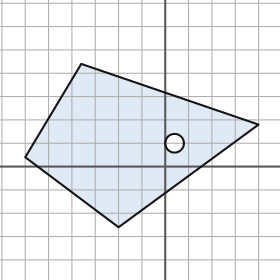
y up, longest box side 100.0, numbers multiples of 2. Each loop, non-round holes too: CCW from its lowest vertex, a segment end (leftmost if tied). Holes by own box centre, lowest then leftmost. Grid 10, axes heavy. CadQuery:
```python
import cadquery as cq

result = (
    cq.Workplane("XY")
    .moveTo(-20.0, -26.0)
    .lineTo(40.0, 18.0)
    .lineTo(-36.0, 44.0)
    .lineTo(-60.0, 4.0)
    .close()
    .moveTo(4.0, 10.0)
    .circle(4.0)
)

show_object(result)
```